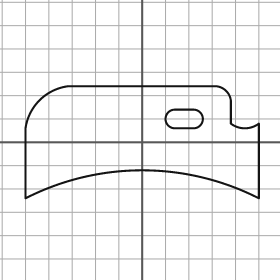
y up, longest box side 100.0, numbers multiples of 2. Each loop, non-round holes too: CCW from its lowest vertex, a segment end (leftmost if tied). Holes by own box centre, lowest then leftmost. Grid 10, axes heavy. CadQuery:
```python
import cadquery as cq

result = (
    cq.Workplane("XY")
    .moveTo(-50.0, -24.0)
    .threePointArc((0.0, -12.0), (50.0, -24.0))
    .lineTo(50.0, 8.0)
    .threePointArc((44.0, 6.0), (38.0, 8.0))
    .lineTo(38.0, 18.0)
    .threePointArc((36.0, 22.0), (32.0, 24.0))
    .lineTo(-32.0, 24.0)
    .threePointArc((-44.0, 18.0), (-50.0, 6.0))
    .close()
    .moveTo(14.0, 6.0)
    .lineTo(22.0, 6.0)
    .threePointArc((26.0, 10.0), (22.0, 14.0))
    .lineTo(14.0, 14.0)
    .threePointArc((10.0, 10.0), (14.0, 6.0))
    .close()
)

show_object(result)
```